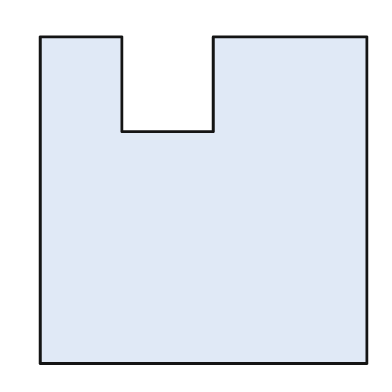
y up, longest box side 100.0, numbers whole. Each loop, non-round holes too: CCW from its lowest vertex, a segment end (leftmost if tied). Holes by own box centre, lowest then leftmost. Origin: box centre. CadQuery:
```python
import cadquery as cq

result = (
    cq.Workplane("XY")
    .moveTo(-50.0, -50.0)
    .lineTo(50.0, -50.0)
    .lineTo(50.0, 50.0)
    .lineTo(3.0, 50.0)
    .lineTo(3.0, 21.0)
    .lineTo(-25.0, 21.0)
    .lineTo(-25.0, 50.0)
    .lineTo(-50.0, 50.0)
    .close()
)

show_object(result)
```